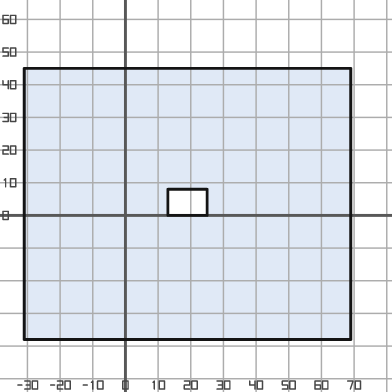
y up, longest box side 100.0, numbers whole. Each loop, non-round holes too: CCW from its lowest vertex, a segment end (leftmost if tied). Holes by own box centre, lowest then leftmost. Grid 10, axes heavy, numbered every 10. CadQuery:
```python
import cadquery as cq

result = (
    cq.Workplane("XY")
    .moveTo(-31.0, -38.0)
    .lineTo(69.0, -38.0)
    .lineTo(69.0, 45.0)
    .lineTo(-31.0, 45.0)
    .close()
    .moveTo(13.0, 0.0)
    .lineTo(25.0, 0.0)
    .lineTo(25.0, 8.0)
    .lineTo(13.0, 8.0)
    .close()
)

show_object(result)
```